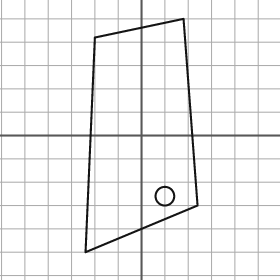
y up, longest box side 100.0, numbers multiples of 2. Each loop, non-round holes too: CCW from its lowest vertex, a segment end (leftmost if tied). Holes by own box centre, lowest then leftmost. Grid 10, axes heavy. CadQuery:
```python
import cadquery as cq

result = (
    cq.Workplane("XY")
    .moveTo(-24.0, -50.0)
    .lineTo(24.0, -30.0)
    .lineTo(18.0, 50.0)
    .lineTo(-20.0, 42.0)
    .close()
    .moveTo(10.0, -26.0)
    .circle(4.0)
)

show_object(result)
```